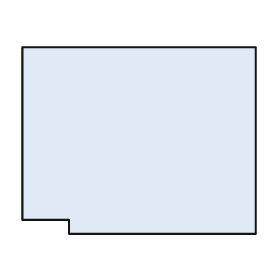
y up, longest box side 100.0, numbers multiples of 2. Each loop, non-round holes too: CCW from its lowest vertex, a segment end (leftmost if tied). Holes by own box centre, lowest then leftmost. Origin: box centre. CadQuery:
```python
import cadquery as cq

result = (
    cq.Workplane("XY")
    .moveTo(-30.0, -40.0)
    .lineTo(50.0, -40.0)
    .lineTo(50.0, 40.0)
    .lineTo(-50.0, 40.0)
    .lineTo(-50.0, -34.0)
    .lineTo(-30.0, -34.0)
    .close()
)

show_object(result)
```